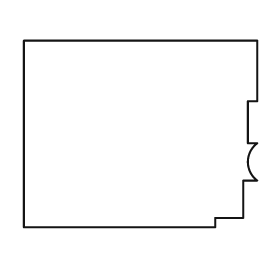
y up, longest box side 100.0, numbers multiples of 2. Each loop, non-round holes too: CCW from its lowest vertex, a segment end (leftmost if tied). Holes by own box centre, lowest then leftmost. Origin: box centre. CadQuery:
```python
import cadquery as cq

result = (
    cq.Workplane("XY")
    .moveTo(-50.0, -40.0)
    .lineTo(32.0, -40.0)
    .lineTo(32.0, -36.0)
    .lineTo(44.0, -36.0)
    .lineTo(44.0, -20.0)
    .lineTo(50.0, -20.0)
    .threePointArc((46.0, -12.0), (50.0, -4.0))
    .lineTo(46.0, -4.0)
    .lineTo(46.0, 14.0)
    .lineTo(50.0, 14.0)
    .lineTo(50.0, 40.0)
    .lineTo(-50.0, 40.0)
    .close()
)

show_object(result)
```